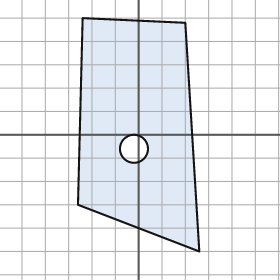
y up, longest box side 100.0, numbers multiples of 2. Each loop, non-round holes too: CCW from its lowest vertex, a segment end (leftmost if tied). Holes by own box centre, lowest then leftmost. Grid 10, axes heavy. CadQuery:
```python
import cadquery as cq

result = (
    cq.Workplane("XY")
    .moveTo(26.0, -50.0)
    .lineTo(20.0, 48.0)
    .lineTo(-24.0, 50.0)
    .lineTo(-26.0, -30.0)
    .close()
    .moveTo(-2.0, -6.0)
    .circle(6.0)
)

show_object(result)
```